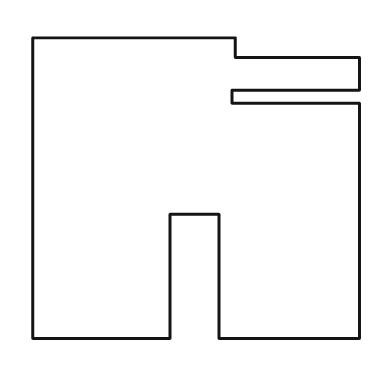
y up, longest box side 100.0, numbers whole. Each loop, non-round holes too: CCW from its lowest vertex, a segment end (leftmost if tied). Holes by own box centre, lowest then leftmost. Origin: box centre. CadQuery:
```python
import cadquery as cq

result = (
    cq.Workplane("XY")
    .moveTo(-50.0, -46.0)
    .lineTo(-8.0, -46.0)
    .lineTo(-8.0, -8.0)
    .lineTo(7.0, -8.0)
    .lineTo(7.0, -46.0)
    .lineTo(50.0, -46.0)
    .lineTo(50.0, 26.0)
    .lineTo(11.0, 26.0)
    .lineTo(11.0, 30.0)
    .lineTo(50.0, 30.0)
    .lineTo(50.0, 40.0)
    .lineTo(12.0, 40.0)
    .lineTo(12.0, 46.0)
    .lineTo(-50.0, 46.0)
    .close()
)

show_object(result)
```